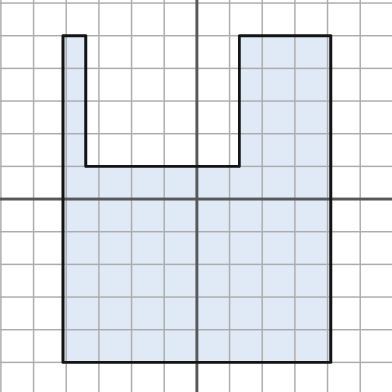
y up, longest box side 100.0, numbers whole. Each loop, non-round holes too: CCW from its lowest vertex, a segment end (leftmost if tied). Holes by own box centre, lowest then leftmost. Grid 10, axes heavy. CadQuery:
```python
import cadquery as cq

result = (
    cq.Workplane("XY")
    .moveTo(-41.0, -50.0)
    .lineTo(41.0, -50.0)
    .lineTo(41.0, 50.0)
    .lineTo(13.0, 50.0)
    .lineTo(13.0, 10.0)
    .lineTo(-34.0, 10.0)
    .lineTo(-34.0, 50.0)
    .lineTo(-41.0, 50.0)
    .close()
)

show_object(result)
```